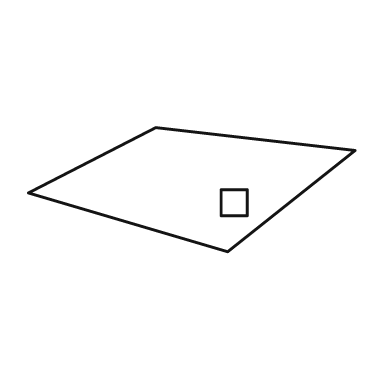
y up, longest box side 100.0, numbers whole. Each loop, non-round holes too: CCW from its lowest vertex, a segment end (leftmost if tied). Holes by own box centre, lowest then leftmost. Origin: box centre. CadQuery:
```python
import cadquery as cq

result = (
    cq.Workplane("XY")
    .moveTo(11.0, -19.0)
    .lineTo(50.0, 12.0)
    .lineTo(-11.0, 19.0)
    .lineTo(-50.0, -1.0)
    .close()
    .moveTo(9.0, -8.0)
    .lineTo(17.0, -8.0)
    .lineTo(17.0, 0.0)
    .lineTo(9.0, 0.0)
    .close()
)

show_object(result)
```